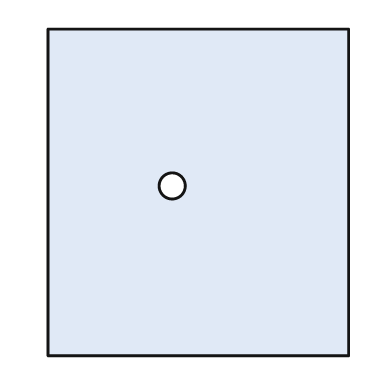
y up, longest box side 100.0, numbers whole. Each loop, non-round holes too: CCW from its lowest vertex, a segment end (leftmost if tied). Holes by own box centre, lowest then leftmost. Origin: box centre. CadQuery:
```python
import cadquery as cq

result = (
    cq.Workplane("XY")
    .moveTo(-46.0, -50.0)
    .lineTo(46.0, -50.0)
    .lineTo(46.0, 50.0)
    .lineTo(-46.0, 50.0)
    .close()
    .moveTo(-8.0, 2.0)
    .circle(4.0)
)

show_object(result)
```